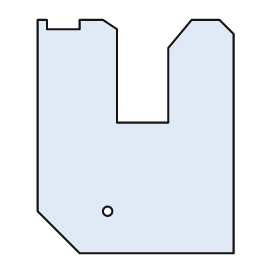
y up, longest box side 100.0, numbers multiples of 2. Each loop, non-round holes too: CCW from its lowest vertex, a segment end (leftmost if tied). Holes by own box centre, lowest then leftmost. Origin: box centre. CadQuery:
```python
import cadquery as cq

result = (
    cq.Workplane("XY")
    .moveTo(-24.0, -50.0)
    .lineTo(42.0, -50.0)
    .lineTo(42.0, 44.0)
    .lineTo(36.0, 50.0)
    .lineTo(24.0, 50.0)
    .lineTo(14.0, 38.0)
    .lineTo(14.0, 6.0)
    .lineTo(-8.0, 6.0)
    .lineTo(-8.0, 46.0)
    .lineTo(-14.0, 50.0)
    .lineTo(-24.0, 50.0)
    .lineTo(-24.0, 46.0)
    .lineTo(-38.0, 46.0)
    .lineTo(-38.0, 50.0)
    .lineTo(-42.0, 50.0)
    .lineTo(-42.0, -32.0)
    .close()
    .moveTo(-12.0, -32.0)
    .circle(2.0)
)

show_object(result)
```